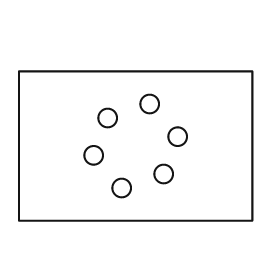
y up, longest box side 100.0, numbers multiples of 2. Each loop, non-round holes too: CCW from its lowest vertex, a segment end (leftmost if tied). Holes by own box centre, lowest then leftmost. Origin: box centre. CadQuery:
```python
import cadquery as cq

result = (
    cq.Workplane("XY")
    .moveTo(-50.0, -32.0)
    .lineTo(50.0, -32.0)
    .lineTo(50.0, 32.0)
    .lineTo(-50.0, 32.0)
    .close()
    .moveTo(-6.0, -18.0)
    .circle(4.0)
    .moveTo(12.0, -12.0)
    .circle(4.0)
    .moveTo(-18.0, -4.0)
    .circle(4.0)
    .moveTo(18.0, 4.0)
    .circle(4.0)
    .moveTo(-12.0, 12.0)
    .circle(4.0)
    .moveTo(6.0, 18.0)
    .circle(4.0)
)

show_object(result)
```